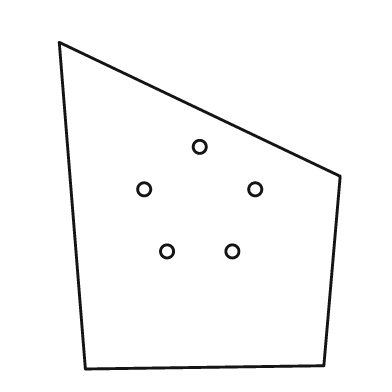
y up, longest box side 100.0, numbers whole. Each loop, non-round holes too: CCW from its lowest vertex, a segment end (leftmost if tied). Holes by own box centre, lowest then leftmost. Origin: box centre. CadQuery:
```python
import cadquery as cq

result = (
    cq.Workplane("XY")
    .moveTo(-35.0, -50.0)
    .lineTo(38.0, -49.0)
    .lineTo(43.0, 9.0)
    .lineTo(-43.0, 50.0)
    .close()
    .moveTo(-10.0, -14.0)
    .circle(2.0)
    .moveTo(10.0, -14.0)
    .circle(2.0)
    .moveTo(-17.0, 5.0)
    .circle(2.0)
    .moveTo(17.0, 5.0)
    .circle(2.0)
    .moveTo(0.0, 18.0)
    .circle(2.0)
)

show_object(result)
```